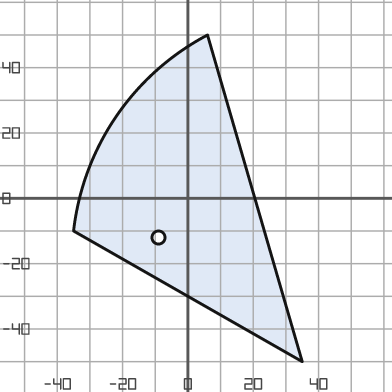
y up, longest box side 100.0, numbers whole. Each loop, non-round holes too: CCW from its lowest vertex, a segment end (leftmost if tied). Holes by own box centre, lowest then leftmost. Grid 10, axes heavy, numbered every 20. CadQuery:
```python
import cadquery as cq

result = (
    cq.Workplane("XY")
    .moveTo(35.0, -50.0)
    .lineTo(6.0, 50.0)
    .threePointArc((-22.0, 25.0), (-35.0, -10.0))
    .close()
    .moveTo(-9.0, -12.0)
    .circle(2.0)
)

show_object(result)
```